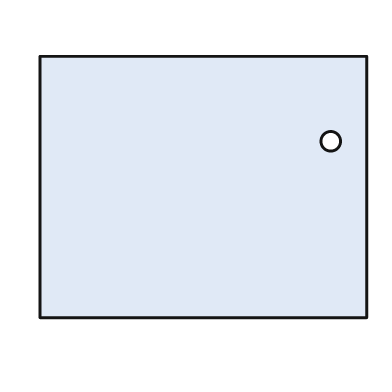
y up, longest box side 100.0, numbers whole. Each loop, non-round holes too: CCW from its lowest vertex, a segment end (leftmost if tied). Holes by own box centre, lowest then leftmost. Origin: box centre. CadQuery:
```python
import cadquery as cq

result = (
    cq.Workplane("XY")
    .moveTo(-50.0, -40.0)
    .lineTo(50.0, -40.0)
    .lineTo(50.0, 40.0)
    .lineTo(-50.0, 40.0)
    .close()
    .moveTo(39.0, 14.0)
    .circle(3.0)
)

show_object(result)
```